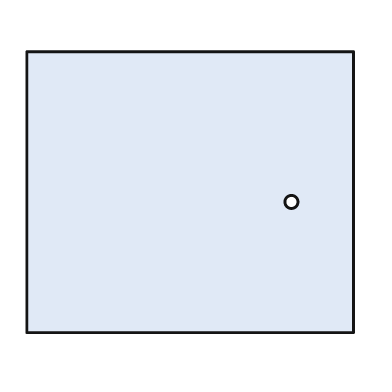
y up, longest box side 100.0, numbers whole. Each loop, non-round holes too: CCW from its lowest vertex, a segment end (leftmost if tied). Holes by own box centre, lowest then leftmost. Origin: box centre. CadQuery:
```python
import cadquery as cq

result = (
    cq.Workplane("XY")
    .moveTo(-50.0, -43.0)
    .lineTo(50.0, -43.0)
    .lineTo(50.0, 43.0)
    .lineTo(-50.0, 43.0)
    .close()
    .moveTo(31.0, -3.0)
    .circle(2.0)
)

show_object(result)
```